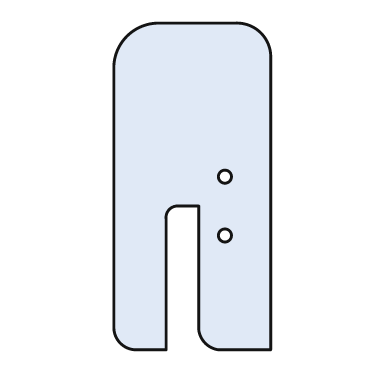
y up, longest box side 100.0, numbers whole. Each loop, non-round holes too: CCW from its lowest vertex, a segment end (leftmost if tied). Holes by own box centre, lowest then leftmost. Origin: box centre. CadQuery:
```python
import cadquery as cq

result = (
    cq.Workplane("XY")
    .moveTo(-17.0, -50.0)
    .lineTo(-8.0, -50.0)
    .lineTo(-8.0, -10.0)
    .threePointArc((-7.0, -7.0), (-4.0, -6.0))
    .lineTo(2.0, -6.0)
    .lineTo(2.0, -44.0)
    .threePointArc((4.0, -48.0), (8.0, -50.0))
    .lineTo(24.0, -50.0)
    .lineTo(24.0, 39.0)
    .threePointArc((21.0, 47.0), (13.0, 50.0))
    .lineTo(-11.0, 50.0)
    .threePointArc((-20.0, 46.0), (-24.0, 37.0))
    .lineTo(-24.0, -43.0)
    .threePointArc((-22.0, -48.0), (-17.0, -50.0))
    .close()
    .moveTo(10.0, -15.0)
    .circle(2.0)
    .moveTo(10.0, 3.0)
    .circle(2.0)
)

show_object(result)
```